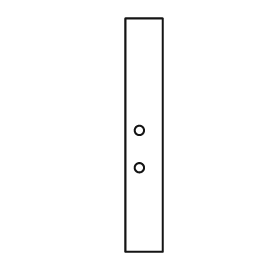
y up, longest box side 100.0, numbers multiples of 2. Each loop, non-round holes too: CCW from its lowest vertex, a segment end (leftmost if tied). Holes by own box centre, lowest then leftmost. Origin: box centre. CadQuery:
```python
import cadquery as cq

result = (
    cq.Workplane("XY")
    .moveTo(-8.0, -50.0)
    .lineTo(8.0, -50.0)
    .lineTo(8.0, 50.0)
    .lineTo(-8.0, 50.0)
    .close()
    .moveTo(-2.0, -14.0)
    .circle(2.0)
    .moveTo(-2.0, 2.0)
    .circle(2.0)
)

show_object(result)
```